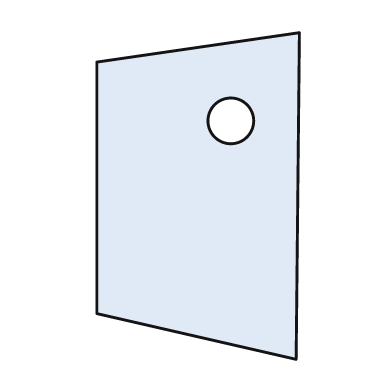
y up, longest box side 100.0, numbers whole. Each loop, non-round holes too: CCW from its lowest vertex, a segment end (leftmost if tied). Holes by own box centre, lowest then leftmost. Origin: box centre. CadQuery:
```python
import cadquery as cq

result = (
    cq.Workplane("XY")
    .moveTo(30.0, -50.0)
    .lineTo(31.0, 50.0)
    .lineTo(-31.0, 41.0)
    .lineTo(-31.0, -36.0)
    .close()
    .moveTo(10.0, 23.0)
    .circle(7.0)
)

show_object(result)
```